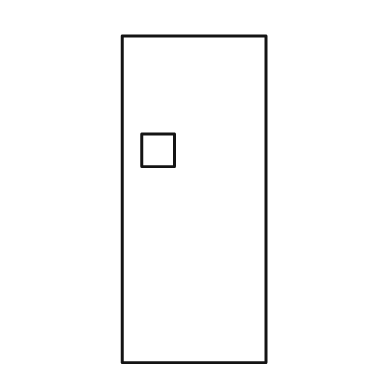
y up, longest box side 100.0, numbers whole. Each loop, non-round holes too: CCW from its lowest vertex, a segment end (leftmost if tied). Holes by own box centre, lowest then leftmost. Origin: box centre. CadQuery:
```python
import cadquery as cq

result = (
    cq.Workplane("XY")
    .moveTo(-22.0, -50.0)
    .lineTo(22.0, -50.0)
    .lineTo(22.0, 50.0)
    .lineTo(-22.0, 50.0)
    .close()
    .moveTo(-16.0, 10.0)
    .lineTo(-6.0, 10.0)
    .lineTo(-6.0, 20.0)
    .lineTo(-16.0, 20.0)
    .close()
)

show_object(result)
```